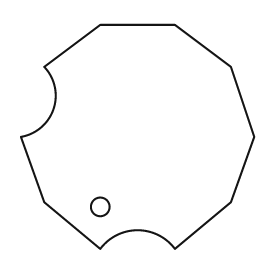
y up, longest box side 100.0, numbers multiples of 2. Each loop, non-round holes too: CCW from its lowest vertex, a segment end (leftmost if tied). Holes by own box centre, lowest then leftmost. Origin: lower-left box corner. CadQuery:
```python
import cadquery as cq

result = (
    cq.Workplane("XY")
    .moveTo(34.0, 0.0)
    .threePointArc((50.0, 8.0), (66.0, 0.0))
    .lineTo(90.0, 20.0)
    .lineTo(100.0, 48.0)
    .lineTo(90.0, 78.0)
    .lineTo(66.0, 96.0)
    .lineTo(34.0, 96.0)
    .lineTo(10.0, 78.0)
    .threePointArc((14.0, 60.0), (0.0, 48.0))
    .lineTo(10.0, 20.0)
    .close()
    .moveTo(34.0, 18.0)
    .circle(4.0)
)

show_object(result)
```